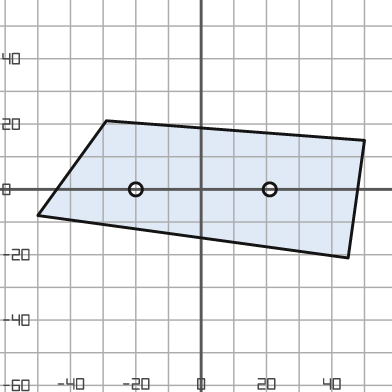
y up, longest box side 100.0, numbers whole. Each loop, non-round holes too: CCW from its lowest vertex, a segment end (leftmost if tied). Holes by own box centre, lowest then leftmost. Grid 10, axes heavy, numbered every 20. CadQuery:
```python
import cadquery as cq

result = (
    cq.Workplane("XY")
    .moveTo(45.0, -21.0)
    .lineTo(50.0, 15.0)
    .lineTo(-29.0, 21.0)
    .lineTo(-50.0, -8.0)
    .close()
    .moveTo(-20.0, 0.0)
    .circle(2.0)
    .moveTo(21.0, 0.0)
    .circle(2.0)
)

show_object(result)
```